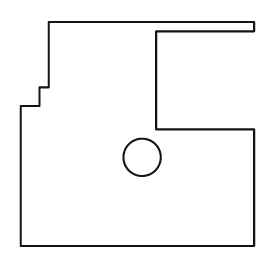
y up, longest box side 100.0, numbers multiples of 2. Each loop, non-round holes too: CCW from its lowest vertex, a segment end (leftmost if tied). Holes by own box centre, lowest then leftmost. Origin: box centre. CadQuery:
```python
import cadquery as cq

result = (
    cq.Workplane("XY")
    .moveTo(-50.0, -48.0)
    .lineTo(50.0, -48.0)
    .lineTo(50.0, 2.0)
    .lineTo(8.0, 2.0)
    .lineTo(8.0, 44.0)
    .lineTo(50.0, 44.0)
    .lineTo(50.0, 48.0)
    .lineTo(-38.0, 48.0)
    .lineTo(-38.0, 20.0)
    .lineTo(-42.0, 20.0)
    .lineTo(-42.0, 12.0)
    .lineTo(-50.0, 12.0)
    .close()
    .moveTo(2.0, -10.0)
    .circle(8.0)
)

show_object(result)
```